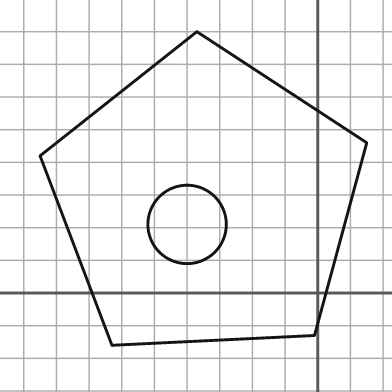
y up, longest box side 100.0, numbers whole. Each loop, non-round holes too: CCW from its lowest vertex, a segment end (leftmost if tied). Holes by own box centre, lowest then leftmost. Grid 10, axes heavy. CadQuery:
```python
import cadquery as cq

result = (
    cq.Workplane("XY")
    .moveTo(-63.0, -16.0)
    .lineTo(-1.0, -13.0)
    .lineTo(15.0, 46.0)
    .lineTo(-37.0, 80.0)
    .lineTo(-85.0, 42.0)
    .close()
    .moveTo(-40.0, 21.0)
    .circle(12.0)
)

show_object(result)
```